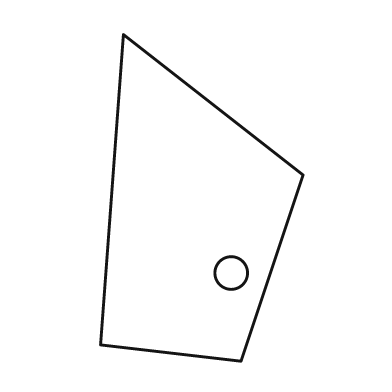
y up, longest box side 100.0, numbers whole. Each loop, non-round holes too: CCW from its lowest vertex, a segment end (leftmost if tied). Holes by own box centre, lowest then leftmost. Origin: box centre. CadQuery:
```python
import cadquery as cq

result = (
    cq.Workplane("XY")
    .moveTo(12.0, -50.0)
    .lineTo(31.0, 7.0)
    .lineTo(-24.0, 50.0)
    .lineTo(-31.0, -45.0)
    .close()
    .moveTo(9.0, -23.0)
    .circle(5.0)
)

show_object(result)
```